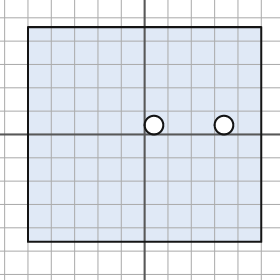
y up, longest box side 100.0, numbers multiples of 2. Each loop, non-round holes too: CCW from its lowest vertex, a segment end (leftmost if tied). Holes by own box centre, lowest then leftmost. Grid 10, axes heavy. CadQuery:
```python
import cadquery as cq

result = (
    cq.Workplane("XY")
    .moveTo(-50.0, -46.0)
    .lineTo(50.0, -46.0)
    .lineTo(50.0, 46.0)
    .lineTo(-50.0, 46.0)
    .close()
    .moveTo(4.0, 4.0)
    .circle(4.0)
    .moveTo(34.0, 4.0)
    .circle(4.0)
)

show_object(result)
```